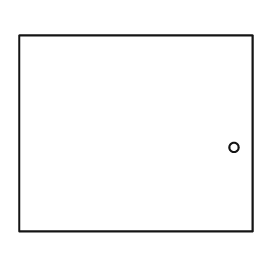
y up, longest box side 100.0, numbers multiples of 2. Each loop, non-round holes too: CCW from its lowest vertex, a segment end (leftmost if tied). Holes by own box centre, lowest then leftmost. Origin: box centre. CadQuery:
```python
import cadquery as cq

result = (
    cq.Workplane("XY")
    .moveTo(-50.0, -42.0)
    .lineTo(50.0, -42.0)
    .lineTo(50.0, 42.0)
    .lineTo(-50.0, 42.0)
    .close()
    .moveTo(42.0, -6.0)
    .circle(2.0)
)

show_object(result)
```